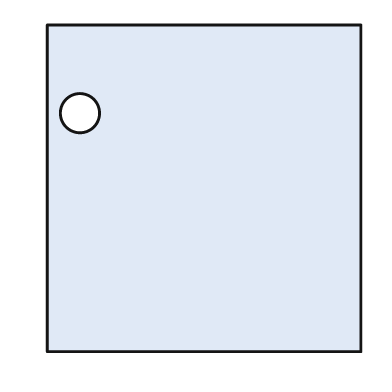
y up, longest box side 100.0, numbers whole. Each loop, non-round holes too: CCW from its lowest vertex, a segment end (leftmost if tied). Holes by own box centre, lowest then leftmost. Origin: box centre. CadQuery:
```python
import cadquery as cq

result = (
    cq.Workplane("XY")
    .moveTo(-48.0, -50.0)
    .lineTo(48.0, -50.0)
    .lineTo(48.0, 50.0)
    .lineTo(-48.0, 50.0)
    .close()
    .moveTo(-38.0, 23.0)
    .circle(6.0)
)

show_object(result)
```